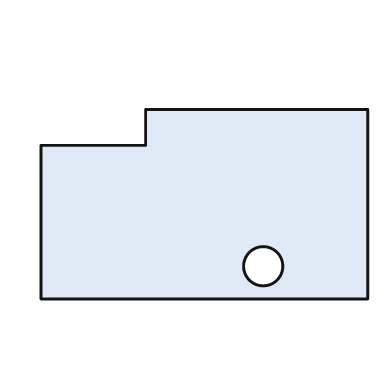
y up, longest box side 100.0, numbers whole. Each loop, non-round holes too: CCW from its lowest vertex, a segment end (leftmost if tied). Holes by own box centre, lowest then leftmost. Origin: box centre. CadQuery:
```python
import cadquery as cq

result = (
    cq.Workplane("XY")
    .moveTo(-50.0, -29.0)
    .lineTo(50.0, -29.0)
    .lineTo(50.0, 29.0)
    .lineTo(-18.0, 29.0)
    .lineTo(-18.0, 18.0)
    .lineTo(-50.0, 18.0)
    .close()
    .moveTo(18.0, -19.0)
    .circle(6.0)
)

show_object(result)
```